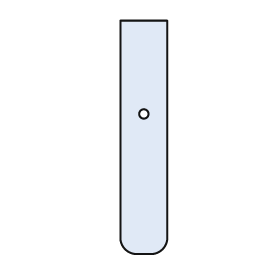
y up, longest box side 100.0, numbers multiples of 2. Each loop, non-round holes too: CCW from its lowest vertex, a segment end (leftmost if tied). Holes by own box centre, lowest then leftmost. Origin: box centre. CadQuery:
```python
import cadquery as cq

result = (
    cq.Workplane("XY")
    .moveTo(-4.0, -50.0)
    .lineTo(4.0, -50.0)
    .threePointArc((8.0, -48.0), (10.0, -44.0))
    .lineTo(10.0, 50.0)
    .lineTo(-10.0, 50.0)
    .lineTo(-10.0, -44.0)
    .threePointArc((-8.0, -48.0), (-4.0, -50.0))
    .close()
    .moveTo(0.0, 10.0)
    .circle(2.0)
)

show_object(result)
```